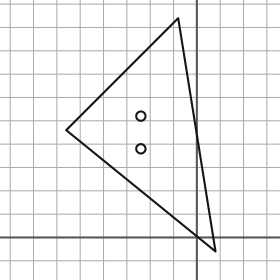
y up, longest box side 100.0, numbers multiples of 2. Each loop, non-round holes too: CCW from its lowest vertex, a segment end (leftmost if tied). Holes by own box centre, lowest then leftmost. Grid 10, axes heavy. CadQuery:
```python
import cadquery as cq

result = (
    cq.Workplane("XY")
    .moveTo(8.0, -6.0)
    .lineTo(-8.0, 94.0)
    .lineTo(-56.0, 46.0)
    .close()
    .moveTo(-24.0, 38.0)
    .circle(2.0)
    .moveTo(-24.0, 52.0)
    .circle(2.0)
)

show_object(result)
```